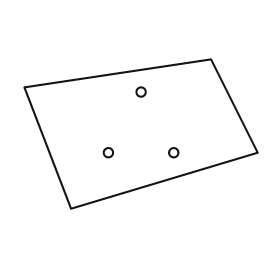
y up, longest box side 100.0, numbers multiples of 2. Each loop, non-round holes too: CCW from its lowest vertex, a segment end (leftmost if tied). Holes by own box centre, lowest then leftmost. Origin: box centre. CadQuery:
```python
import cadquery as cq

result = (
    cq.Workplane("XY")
    .moveTo(-30.0, -32.0)
    .lineTo(50.0, -8.0)
    .lineTo(30.0, 32.0)
    .lineTo(-50.0, 20.0)
    .close()
    .moveTo(-14.0, -8.0)
    .circle(2.0)
    .moveTo(14.0, -8.0)
    .circle(2.0)
    .moveTo(0.0, 18.0)
    .circle(2.0)
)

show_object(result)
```